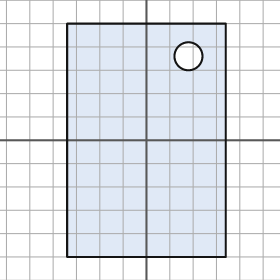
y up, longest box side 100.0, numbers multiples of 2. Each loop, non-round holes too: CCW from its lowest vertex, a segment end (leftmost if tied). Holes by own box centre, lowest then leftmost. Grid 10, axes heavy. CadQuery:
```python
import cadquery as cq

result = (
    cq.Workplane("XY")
    .moveTo(-34.0, -50.0)
    .lineTo(34.0, -50.0)
    .lineTo(34.0, 50.0)
    .lineTo(-34.0, 50.0)
    .close()
    .moveTo(18.0, 36.0)
    .circle(6.0)
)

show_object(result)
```